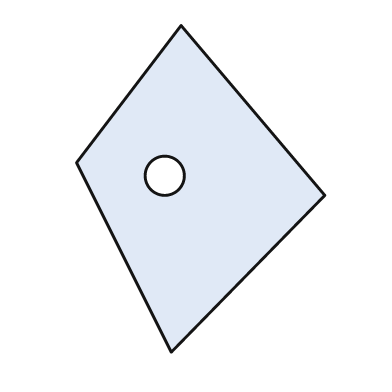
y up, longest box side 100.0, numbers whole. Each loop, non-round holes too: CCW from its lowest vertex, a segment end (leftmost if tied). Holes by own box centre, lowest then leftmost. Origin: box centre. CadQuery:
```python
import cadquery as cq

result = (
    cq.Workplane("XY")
    .moveTo(-9.0, -50.0)
    .lineTo(38.0, -2.0)
    .lineTo(-6.0, 50.0)
    .lineTo(-38.0, 8.0)
    .close()
    .moveTo(-11.0, 4.0)
    .circle(6.0)
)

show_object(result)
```